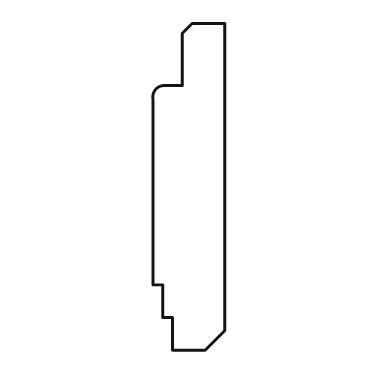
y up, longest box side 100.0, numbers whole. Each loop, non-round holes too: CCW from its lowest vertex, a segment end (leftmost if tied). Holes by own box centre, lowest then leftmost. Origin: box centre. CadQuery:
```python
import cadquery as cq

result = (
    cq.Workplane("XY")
    .moveTo(-5.0, -50.0)
    .lineTo(5.0, -50.0)
    .lineTo(11.0, -44.0)
    .lineTo(11.0, 50.0)
    .lineTo(1.0, 50.0)
    .lineTo(-2.0, 47.0)
    .lineTo(-2.0, 31.0)
    .lineTo(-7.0, 31.0)
    .threePointArc((-10.0, 30.0), (-11.0, 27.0))
    .lineTo(-11.0, -30.0)
    .lineTo(-8.0, -30.0)
    .lineTo(-8.0, -40.0)
    .lineTo(-5.0, -40.0)
    .close()
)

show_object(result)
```